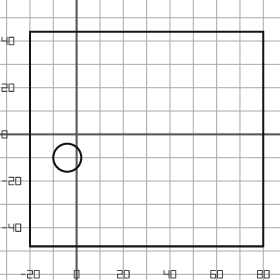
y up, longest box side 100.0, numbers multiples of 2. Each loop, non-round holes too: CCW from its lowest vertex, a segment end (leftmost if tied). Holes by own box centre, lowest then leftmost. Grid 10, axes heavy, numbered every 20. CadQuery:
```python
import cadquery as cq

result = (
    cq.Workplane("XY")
    .moveTo(-20.0, -48.0)
    .lineTo(80.0, -48.0)
    .lineTo(80.0, 44.0)
    .lineTo(-20.0, 44.0)
    .close()
    .moveTo(-4.0, -10.0)
    .circle(6.0)
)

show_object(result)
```